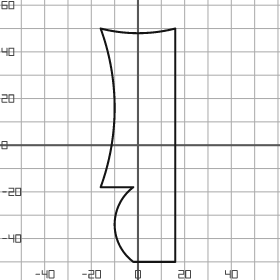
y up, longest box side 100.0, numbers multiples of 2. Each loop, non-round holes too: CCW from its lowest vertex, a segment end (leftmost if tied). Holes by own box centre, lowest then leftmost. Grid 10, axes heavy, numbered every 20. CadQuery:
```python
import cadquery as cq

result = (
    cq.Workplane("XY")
    .moveTo(-2.0, -50.0)
    .lineTo(16.0, -50.0)
    .lineTo(16.0, 50.0)
    .threePointArc((0.0, 48.0), (-16.0, 50.0))
    .threePointArc((-10.0, 16.0), (-16.0, -18.0))
    .lineTo(-2.0, -18.0)
    .threePointArc((-10.0, -34.0), (-2.0, -50.0))
    .close()
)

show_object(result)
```